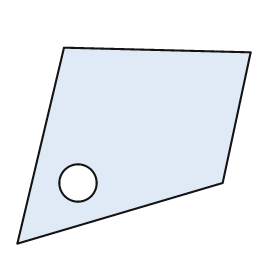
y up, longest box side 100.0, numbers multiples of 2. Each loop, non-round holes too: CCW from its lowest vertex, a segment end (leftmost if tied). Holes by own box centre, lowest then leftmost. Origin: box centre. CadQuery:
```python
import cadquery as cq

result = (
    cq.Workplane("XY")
    .moveTo(-50.0, -42.0)
    .lineTo(38.0, -16.0)
    .lineTo(50.0, 40.0)
    .lineTo(-30.0, 42.0)
    .close()
    .moveTo(-24.0, -16.0)
    .circle(8.0)
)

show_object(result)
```